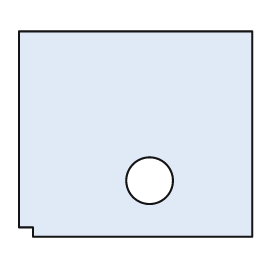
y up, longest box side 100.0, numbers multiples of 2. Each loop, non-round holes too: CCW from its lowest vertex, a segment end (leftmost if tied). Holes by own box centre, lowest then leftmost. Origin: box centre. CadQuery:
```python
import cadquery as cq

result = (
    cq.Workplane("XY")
    .moveTo(-44.0, -44.0)
    .lineTo(50.0, -44.0)
    .lineTo(50.0, 44.0)
    .lineTo(-50.0, 44.0)
    .lineTo(-50.0, -40.0)
    .lineTo(-44.0, -40.0)
    .close()
    .moveTo(6.0, -20.0)
    .circle(10.0)
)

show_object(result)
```